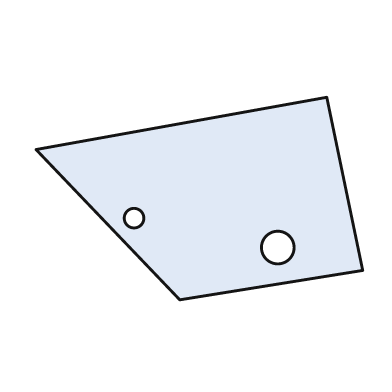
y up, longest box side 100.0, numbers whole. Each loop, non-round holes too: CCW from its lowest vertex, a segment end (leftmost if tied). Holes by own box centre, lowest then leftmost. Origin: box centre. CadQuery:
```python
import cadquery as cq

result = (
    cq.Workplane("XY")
    .moveTo(-6.0, -31.0)
    .lineTo(50.0, -22.0)
    .lineTo(39.0, 31.0)
    .lineTo(-50.0, 15.0)
    .close()
    .moveTo(24.0, -15.0)
    .circle(5.0)
    .moveTo(-20.0, -6.0)
    .circle(3.0)
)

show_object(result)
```